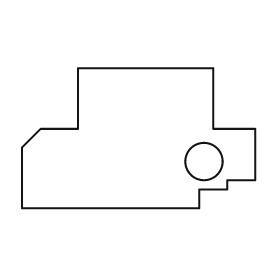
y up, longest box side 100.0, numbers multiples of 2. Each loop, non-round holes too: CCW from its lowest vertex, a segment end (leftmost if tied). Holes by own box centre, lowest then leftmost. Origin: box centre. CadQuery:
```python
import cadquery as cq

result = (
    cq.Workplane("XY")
    .moveTo(-50.0, -30.0)
    .lineTo(26.0, -30.0)
    .lineTo(26.0, -22.0)
    .lineTo(38.0, -22.0)
    .lineTo(38.0, -18.0)
    .lineTo(50.0, -18.0)
    .lineTo(50.0, 4.0)
    .lineTo(32.0, 4.0)
    .lineTo(32.0, 30.0)
    .lineTo(-26.0, 30.0)
    .lineTo(-26.0, 4.0)
    .lineTo(-42.0, 4.0)
    .lineTo(-50.0, -4.0)
    .close()
    .moveTo(28.0, -10.0)
    .circle(8.0)
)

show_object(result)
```